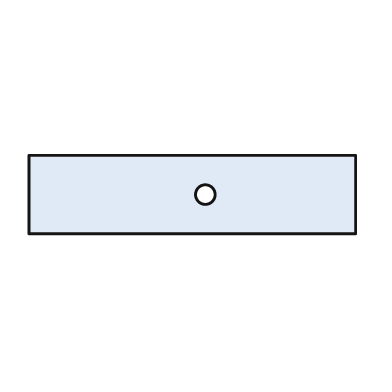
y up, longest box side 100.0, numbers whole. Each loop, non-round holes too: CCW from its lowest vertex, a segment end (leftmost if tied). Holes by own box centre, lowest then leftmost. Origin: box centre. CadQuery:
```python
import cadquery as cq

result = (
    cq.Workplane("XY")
    .moveTo(-50.0, -12.0)
    .lineTo(50.0, -12.0)
    .lineTo(50.0, 12.0)
    .lineTo(-50.0, 12.0)
    .close()
    .moveTo(4.0, 0.0)
    .circle(3.0)
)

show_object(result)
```